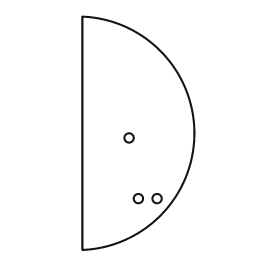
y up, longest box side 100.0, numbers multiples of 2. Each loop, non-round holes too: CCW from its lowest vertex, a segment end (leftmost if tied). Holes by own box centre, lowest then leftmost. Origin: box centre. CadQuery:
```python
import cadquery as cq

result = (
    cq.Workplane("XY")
    .moveTo(-24.0, -50.0)
    .threePointArc((24.0, 0.0), (-24.0, 50.0))
    .close()
    .moveTo(0.0, -28.0)
    .circle(2.0)
    .moveTo(8.0, -28.0)
    .circle(2.0)
    .moveTo(-4.0, -2.0)
    .circle(2.0)
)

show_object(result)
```